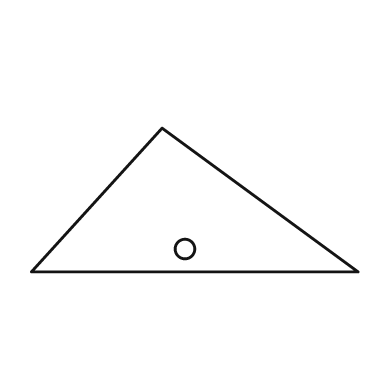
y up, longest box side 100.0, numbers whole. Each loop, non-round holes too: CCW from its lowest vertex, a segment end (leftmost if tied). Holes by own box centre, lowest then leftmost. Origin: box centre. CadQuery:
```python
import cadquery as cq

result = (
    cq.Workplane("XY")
    .moveTo(-50.0, -22.0)
    .lineTo(50.0, -22.0)
    .lineTo(-10.0, 22.0)
    .close()
    .moveTo(-3.0, -15.0)
    .circle(3.0)
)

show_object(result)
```